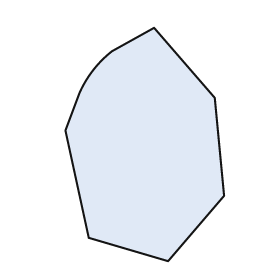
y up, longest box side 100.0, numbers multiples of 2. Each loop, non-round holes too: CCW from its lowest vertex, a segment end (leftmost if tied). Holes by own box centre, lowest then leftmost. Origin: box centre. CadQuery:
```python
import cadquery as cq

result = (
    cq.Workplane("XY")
    .moveTo(10.0, -50.0)
    .lineTo(34.0, -22.0)
    .lineTo(30.0, 20.0)
    .lineTo(4.0, 50.0)
    .lineTo(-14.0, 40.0)
    .threePointArc((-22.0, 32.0), (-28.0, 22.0))
    .lineTo(-34.0, 6.0)
    .lineTo(-24.0, -40.0)
    .close()
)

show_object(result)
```